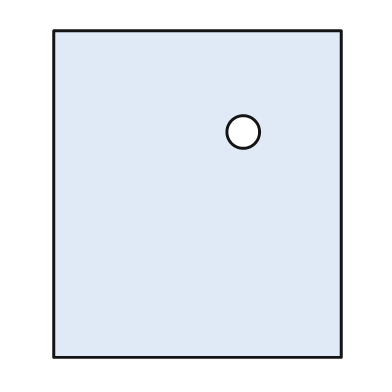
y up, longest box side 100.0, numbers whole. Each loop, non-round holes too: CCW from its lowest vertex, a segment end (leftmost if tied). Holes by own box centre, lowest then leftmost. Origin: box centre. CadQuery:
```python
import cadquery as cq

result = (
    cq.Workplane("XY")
    .moveTo(-44.0, -50.0)
    .lineTo(44.0, -50.0)
    .lineTo(44.0, 50.0)
    .lineTo(-44.0, 50.0)
    .close()
    .moveTo(14.0, 19.0)
    .circle(5.0)
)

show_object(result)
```